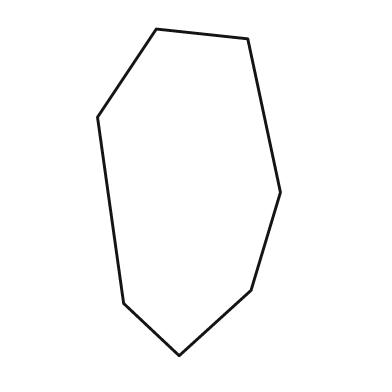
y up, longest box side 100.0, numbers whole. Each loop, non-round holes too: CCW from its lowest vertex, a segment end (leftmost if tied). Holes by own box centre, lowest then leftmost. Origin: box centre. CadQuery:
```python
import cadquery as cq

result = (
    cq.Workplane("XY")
    .moveTo(-3.0, -50.0)
    .lineTo(19.0, -30.0)
    .lineTo(28.0, 0.0)
    .lineTo(18.0, 47.0)
    .lineTo(-10.0, 50.0)
    .lineTo(-28.0, 23.0)
    .lineTo(-20.0, -34.0)
    .close()
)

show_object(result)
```